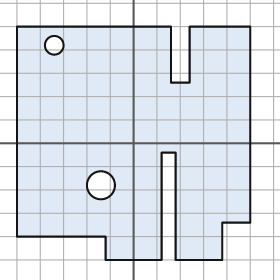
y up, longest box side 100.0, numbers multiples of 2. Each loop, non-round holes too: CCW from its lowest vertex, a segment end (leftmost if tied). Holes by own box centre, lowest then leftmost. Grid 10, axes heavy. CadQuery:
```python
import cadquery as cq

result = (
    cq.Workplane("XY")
    .moveTo(-12.0, -50.0)
    .lineTo(12.0, -50.0)
    .lineTo(12.0, -4.0)
    .lineTo(18.0, -4.0)
    .lineTo(18.0, -50.0)
    .lineTo(38.0, -50.0)
    .lineTo(38.0, -34.0)
    .lineTo(50.0, -34.0)
    .lineTo(50.0, 50.0)
    .lineTo(24.0, 50.0)
    .lineTo(24.0, 26.0)
    .lineTo(16.0, 26.0)
    .lineTo(16.0, 50.0)
    .lineTo(-50.0, 50.0)
    .lineTo(-50.0, -40.0)
    .lineTo(-12.0, -40.0)
    .close()
    .moveTo(-14.0, -18.0)
    .circle(6.0)
    .moveTo(-34.0, 42.0)
    .circle(4.0)
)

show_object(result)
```